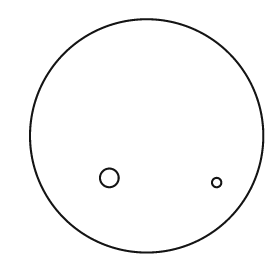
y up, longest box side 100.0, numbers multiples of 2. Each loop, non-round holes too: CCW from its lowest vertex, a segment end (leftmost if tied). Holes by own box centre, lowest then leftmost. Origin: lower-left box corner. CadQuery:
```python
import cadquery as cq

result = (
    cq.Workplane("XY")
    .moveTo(50.0, 50.0)
    .circle(50.0)
    .moveTo(80.0, 30.0)
    .circle(2.0)
    .moveTo(34.0, 32.0)
    .circle(4.0)
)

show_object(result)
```